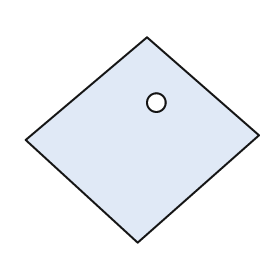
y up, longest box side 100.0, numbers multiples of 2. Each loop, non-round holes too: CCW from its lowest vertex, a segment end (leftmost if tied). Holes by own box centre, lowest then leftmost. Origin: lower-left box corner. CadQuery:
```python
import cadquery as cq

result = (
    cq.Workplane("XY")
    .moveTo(48.0, 0.0)
    .lineTo(100.0, 46.0)
    .lineTo(52.0, 88.0)
    .lineTo(0.0, 44.0)
    .close()
    .moveTo(56.0, 60.0)
    .circle(4.0)
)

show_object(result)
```